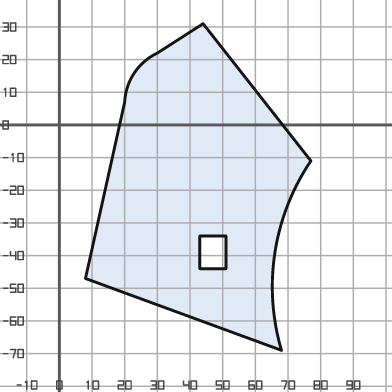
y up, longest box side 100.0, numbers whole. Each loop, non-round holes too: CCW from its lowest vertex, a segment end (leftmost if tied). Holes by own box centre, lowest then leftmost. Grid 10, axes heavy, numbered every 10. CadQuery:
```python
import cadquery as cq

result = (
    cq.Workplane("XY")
    .moveTo(68.0, -69.0)
    .threePointArc((66.0, -39.0), (77.0, -11.0))
    .lineTo(44.0, 31.0)
    .lineTo(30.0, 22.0)
    .threePointArc((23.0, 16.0), (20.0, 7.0))
    .lineTo(8.0, -47.0)
    .close()
    .moveTo(43.0, -44.0)
    .lineTo(51.0, -44.0)
    .lineTo(51.0, -34.0)
    .lineTo(43.0, -34.0)
    .close()
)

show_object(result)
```